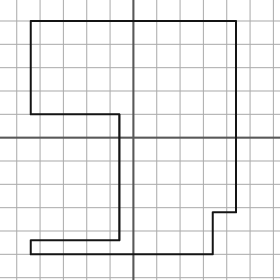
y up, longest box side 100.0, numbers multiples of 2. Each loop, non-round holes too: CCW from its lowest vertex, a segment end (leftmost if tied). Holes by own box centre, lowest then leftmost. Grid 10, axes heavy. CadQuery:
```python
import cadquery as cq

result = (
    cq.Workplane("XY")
    .moveTo(-44.0, -50.0)
    .lineTo(34.0, -50.0)
    .lineTo(34.0, -32.0)
    .lineTo(44.0, -32.0)
    .lineTo(44.0, 50.0)
    .lineTo(-44.0, 50.0)
    .lineTo(-44.0, 10.0)
    .lineTo(-6.0, 10.0)
    .lineTo(-6.0, -44.0)
    .lineTo(-44.0, -44.0)
    .close()
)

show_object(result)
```